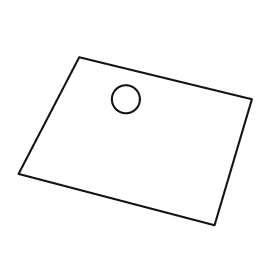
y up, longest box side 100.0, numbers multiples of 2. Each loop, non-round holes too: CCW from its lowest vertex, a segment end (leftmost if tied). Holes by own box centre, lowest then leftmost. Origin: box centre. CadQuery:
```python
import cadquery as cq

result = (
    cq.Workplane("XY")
    .moveTo(34.0, -36.0)
    .lineTo(50.0, 18.0)
    .lineTo(-24.0, 36.0)
    .lineTo(-50.0, -14.0)
    .close()
    .moveTo(-4.0, 18.0)
    .circle(6.0)
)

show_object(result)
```